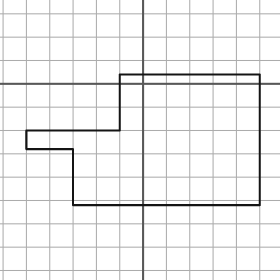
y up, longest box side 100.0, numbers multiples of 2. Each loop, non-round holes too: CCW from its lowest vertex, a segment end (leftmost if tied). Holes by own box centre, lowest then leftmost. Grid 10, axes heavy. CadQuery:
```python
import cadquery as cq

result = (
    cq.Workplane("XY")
    .moveTo(-30.0, -52.0)
    .lineTo(50.0, -52.0)
    .lineTo(50.0, 4.0)
    .lineTo(-10.0, 4.0)
    .lineTo(-10.0, -20.0)
    .lineTo(-50.0, -20.0)
    .lineTo(-50.0, -28.0)
    .lineTo(-30.0, -28.0)
    .close()
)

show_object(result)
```